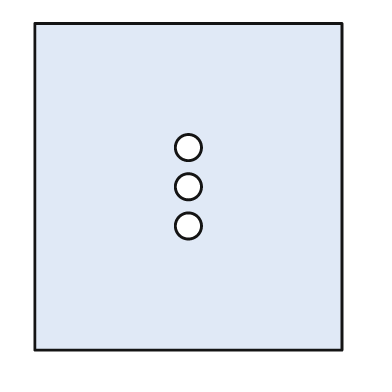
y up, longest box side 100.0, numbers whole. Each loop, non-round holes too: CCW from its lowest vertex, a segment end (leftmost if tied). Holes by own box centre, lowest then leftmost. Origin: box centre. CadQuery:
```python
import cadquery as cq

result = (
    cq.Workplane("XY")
    .moveTo(-47.0, -50.0)
    .lineTo(47.0, -50.0)
    .lineTo(47.0, 50.0)
    .lineTo(-47.0, 50.0)
    .close()
    .moveTo(0.0, -12.0)
    .circle(4.0)
    .moveTo(0.0, 0.0)
    .circle(4.0)
    .moveTo(0.0, 12.0)
    .circle(4.0)
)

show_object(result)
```